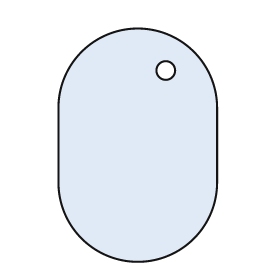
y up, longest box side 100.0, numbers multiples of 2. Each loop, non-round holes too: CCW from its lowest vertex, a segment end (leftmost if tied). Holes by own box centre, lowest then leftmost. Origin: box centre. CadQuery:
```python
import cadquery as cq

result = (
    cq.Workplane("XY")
    .moveTo(-34.0, -16.0)
    .threePointArc((0.0, -50.0), (34.0, -16.0))
    .lineTo(34.0, 16.0)
    .threePointArc((0.0, 50.0), (-34.0, 16.0))
    .close()
    .moveTo(12.0, 32.0)
    .circle(4.0)
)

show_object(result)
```